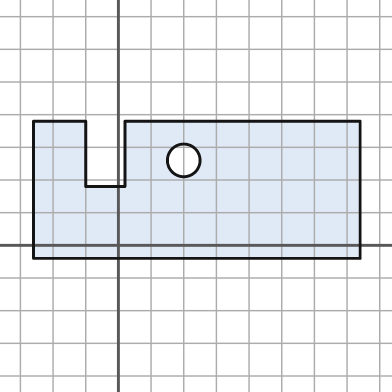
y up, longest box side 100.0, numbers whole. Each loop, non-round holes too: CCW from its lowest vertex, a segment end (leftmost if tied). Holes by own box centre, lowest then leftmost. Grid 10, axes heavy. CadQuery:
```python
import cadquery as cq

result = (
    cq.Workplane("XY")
    .moveTo(-26.0, -4.0)
    .lineTo(74.0, -4.0)
    .lineTo(74.0, 38.0)
    .lineTo(2.0, 38.0)
    .lineTo(2.0, 18.0)
    .lineTo(-10.0, 18.0)
    .lineTo(-10.0, 38.0)
    .lineTo(-26.0, 38.0)
    .close()
    .moveTo(20.0, 26.0)
    .circle(5.0)
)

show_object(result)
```